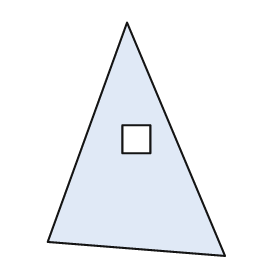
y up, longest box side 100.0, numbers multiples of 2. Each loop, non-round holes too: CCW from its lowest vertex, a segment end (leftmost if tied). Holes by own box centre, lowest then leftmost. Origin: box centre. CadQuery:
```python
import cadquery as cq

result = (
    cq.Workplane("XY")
    .moveTo(38.0, -50.0)
    .lineTo(-4.0, 50.0)
    .lineTo(-38.0, -44.0)
    .close()
    .moveTo(-6.0, -6.0)
    .lineTo(6.0, -6.0)
    .lineTo(6.0, 6.0)
    .lineTo(-6.0, 6.0)
    .close()
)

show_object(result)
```